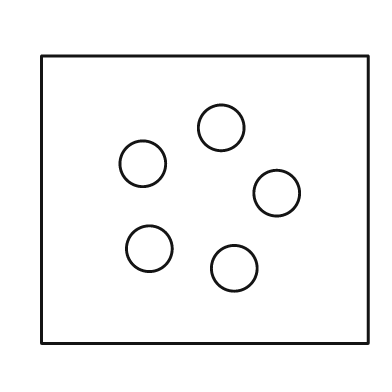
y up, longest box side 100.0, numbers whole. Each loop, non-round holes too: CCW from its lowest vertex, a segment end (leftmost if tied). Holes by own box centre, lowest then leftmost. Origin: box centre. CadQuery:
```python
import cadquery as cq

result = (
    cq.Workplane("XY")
    .moveTo(-50.0, -44.0)
    .lineTo(50.0, -44.0)
    .lineTo(50.0, 44.0)
    .lineTo(-50.0, 44.0)
    .close()
    .moveTo(9.0, -21.0)
    .circle(7.0)
    .moveTo(-17.0, -15.0)
    .circle(7.0)
    .moveTo(22.0, 2.0)
    .circle(7.0)
    .moveTo(-19.0, 11.0)
    .circle(7.0)
    .moveTo(5.0, 22.0)
    .circle(7.0)
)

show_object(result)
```